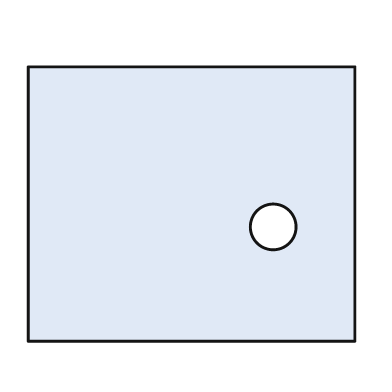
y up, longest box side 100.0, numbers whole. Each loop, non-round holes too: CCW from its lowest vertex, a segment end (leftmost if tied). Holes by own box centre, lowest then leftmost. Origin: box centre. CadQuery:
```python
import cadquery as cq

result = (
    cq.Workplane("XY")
    .moveTo(-50.0, -42.0)
    .lineTo(50.0, -42.0)
    .lineTo(50.0, 42.0)
    .lineTo(-50.0, 42.0)
    .close()
    .moveTo(25.0, -7.0)
    .circle(7.0)
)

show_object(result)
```